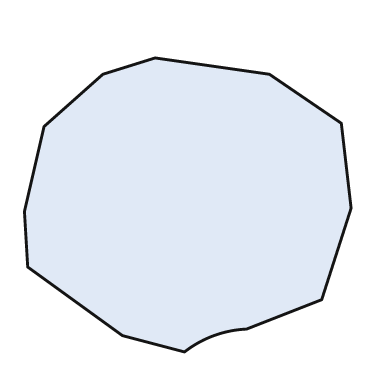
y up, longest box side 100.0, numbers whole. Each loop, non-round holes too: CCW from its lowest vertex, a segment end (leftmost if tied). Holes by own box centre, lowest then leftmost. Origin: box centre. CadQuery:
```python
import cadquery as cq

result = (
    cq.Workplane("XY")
    .moveTo(-1.0, -45.0)
    .threePointArc((8.0, -40.0), (18.0, -38.0))
    .lineTo(41.0, -29.0)
    .lineTo(50.0, -1.0)
    .lineTo(47.0, 25.0)
    .lineTo(25.0, 40.0)
    .lineTo(-10.0, 45.0)
    .lineTo(-26.0, 40.0)
    .lineTo(-44.0, 24.0)
    .lineTo(-50.0, -2.0)
    .lineTo(-49.0, -19.0)
    .lineTo(-20.0, -40.0)
    .close()
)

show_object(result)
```